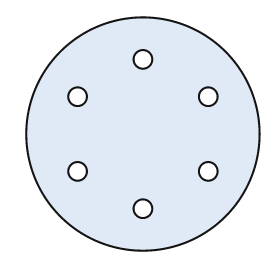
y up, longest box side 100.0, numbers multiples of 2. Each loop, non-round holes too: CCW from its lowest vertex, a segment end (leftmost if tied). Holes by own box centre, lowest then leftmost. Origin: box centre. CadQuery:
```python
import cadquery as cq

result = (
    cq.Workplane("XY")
    .moveTo(0.0, 0.0)
    .circle(50.0)
    .moveTo(0.0, -32.0)
    .circle(4.0)
    .moveTo(-28.0, -16.0)
    .circle(4.0)
    .moveTo(28.0, -16.0)
    .circle(4.0)
    .moveTo(-28.0, 16.0)
    .circle(4.0)
    .moveTo(28.0, 16.0)
    .circle(4.0)
    .moveTo(0.0, 32.0)
    .circle(4.0)
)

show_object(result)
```